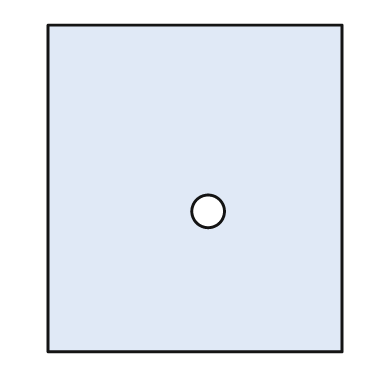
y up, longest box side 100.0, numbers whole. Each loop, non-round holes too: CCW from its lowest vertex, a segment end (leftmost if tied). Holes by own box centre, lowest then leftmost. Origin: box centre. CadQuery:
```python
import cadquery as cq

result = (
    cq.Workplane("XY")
    .moveTo(-45.0, -50.0)
    .lineTo(45.0, -50.0)
    .lineTo(45.0, 50.0)
    .lineTo(-45.0, 50.0)
    .close()
    .moveTo(4.0, -7.0)
    .circle(5.0)
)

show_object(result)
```